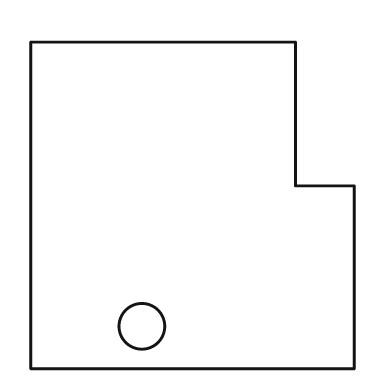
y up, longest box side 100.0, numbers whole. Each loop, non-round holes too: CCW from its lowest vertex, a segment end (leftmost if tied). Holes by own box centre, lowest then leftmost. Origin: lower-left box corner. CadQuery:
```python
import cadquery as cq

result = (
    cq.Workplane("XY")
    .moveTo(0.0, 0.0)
    .lineTo(99.0, 0.0)
    .lineTo(99.0, 56.0)
    .lineTo(81.0, 56.0)
    .lineTo(81.0, 100.0)
    .lineTo(0.0, 100.0)
    .close()
    .moveTo(34.0, 13.0)
    .circle(7.0)
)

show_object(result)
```